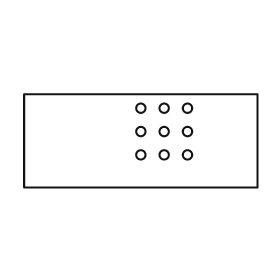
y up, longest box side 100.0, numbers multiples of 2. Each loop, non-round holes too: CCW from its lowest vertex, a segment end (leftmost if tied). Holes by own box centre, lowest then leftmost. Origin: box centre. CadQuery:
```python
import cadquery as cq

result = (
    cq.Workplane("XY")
    .moveTo(-50.0, -20.0)
    .lineTo(50.0, -20.0)
    .lineTo(50.0, 20.0)
    .lineTo(-50.0, 20.0)
    .close()
    .moveTo(0.0, -6.0)
    .circle(2.0)
    .moveTo(10.0, -6.0)
    .circle(2.0)
    .moveTo(20.0, -6.0)
    .circle(2.0)
    .moveTo(0.0, 4.0)
    .circle(2.0)
    .moveTo(10.0, 4.0)
    .circle(2.0)
    .moveTo(20.0, 4.0)
    .circle(2.0)
    .moveTo(0.0, 14.0)
    .circle(2.0)
    .moveTo(10.0, 14.0)
    .circle(2.0)
    .moveTo(20.0, 14.0)
    .circle(2.0)
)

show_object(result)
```